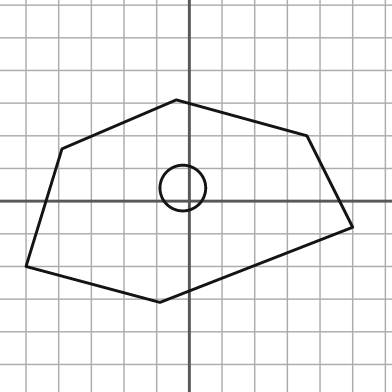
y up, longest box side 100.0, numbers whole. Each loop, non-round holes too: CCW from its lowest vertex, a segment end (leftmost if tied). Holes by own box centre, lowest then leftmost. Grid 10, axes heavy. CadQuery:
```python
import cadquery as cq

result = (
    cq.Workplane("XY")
    .moveTo(-9.0, -31.0)
    .lineTo(50.0, -8.0)
    .lineTo(36.0, 20.0)
    .lineTo(-4.0, 31.0)
    .lineTo(-39.0, 16.0)
    .lineTo(-50.0, -20.0)
    .close()
    .moveTo(-2.0, 4.0)
    .circle(7.0)
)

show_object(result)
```